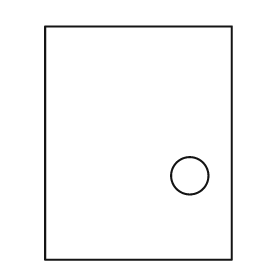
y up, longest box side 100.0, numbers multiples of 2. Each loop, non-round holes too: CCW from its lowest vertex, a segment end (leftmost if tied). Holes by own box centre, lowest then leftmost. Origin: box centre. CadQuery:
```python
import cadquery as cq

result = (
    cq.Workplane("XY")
    .moveTo(-40.0, -50.0)
    .lineTo(40.0, -50.0)
    .lineTo(40.0, 50.0)
    .lineTo(-40.0, 50.0)
    .close()
    .moveTo(22.0, -14.0)
    .circle(8.0)
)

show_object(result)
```